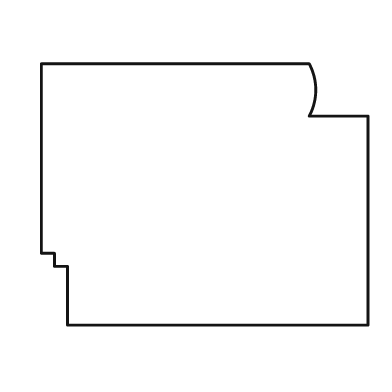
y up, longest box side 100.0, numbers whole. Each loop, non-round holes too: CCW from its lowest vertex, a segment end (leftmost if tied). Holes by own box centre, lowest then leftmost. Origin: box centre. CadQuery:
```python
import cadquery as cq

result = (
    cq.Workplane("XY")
    .moveTo(-42.0, -40.0)
    .lineTo(50.0, -40.0)
    .lineTo(50.0, 24.0)
    .lineTo(32.0, 24.0)
    .threePointArc((34.0, 32.0), (32.0, 40.0))
    .lineTo(-50.0, 40.0)
    .lineTo(-50.0, -18.0)
    .lineTo(-46.0, -18.0)
    .lineTo(-46.0, -22.0)
    .lineTo(-42.0, -22.0)
    .close()
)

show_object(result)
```